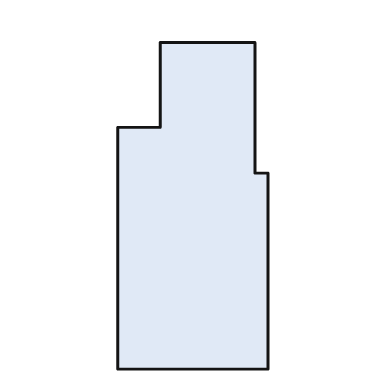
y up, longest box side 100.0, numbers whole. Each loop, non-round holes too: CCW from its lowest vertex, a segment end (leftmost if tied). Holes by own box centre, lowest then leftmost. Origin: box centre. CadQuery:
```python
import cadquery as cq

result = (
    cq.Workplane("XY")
    .moveTo(-23.0, -50.0)
    .lineTo(23.0, -50.0)
    .lineTo(23.0, 10.0)
    .lineTo(19.0, 10.0)
    .lineTo(19.0, 50.0)
    .lineTo(-10.0, 50.0)
    .lineTo(-10.0, 24.0)
    .lineTo(-23.0, 24.0)
    .close()
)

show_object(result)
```